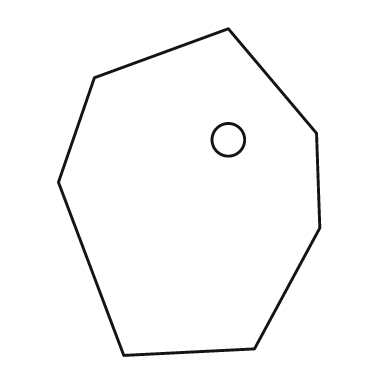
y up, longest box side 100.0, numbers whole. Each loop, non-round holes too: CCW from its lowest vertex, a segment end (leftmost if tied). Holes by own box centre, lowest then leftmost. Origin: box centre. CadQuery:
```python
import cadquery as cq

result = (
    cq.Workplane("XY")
    .moveTo(-20.0, -50.0)
    .lineTo(20.0, -48.0)
    .lineTo(40.0, -11.0)
    .lineTo(39.0, 18.0)
    .lineTo(12.0, 50.0)
    .lineTo(-29.0, 35.0)
    .lineTo(-40.0, 3.0)
    .close()
    .moveTo(12.0, 16.0)
    .circle(5.0)
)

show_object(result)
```